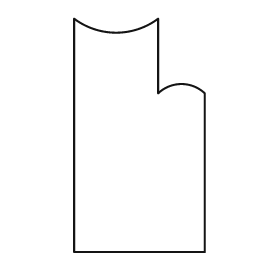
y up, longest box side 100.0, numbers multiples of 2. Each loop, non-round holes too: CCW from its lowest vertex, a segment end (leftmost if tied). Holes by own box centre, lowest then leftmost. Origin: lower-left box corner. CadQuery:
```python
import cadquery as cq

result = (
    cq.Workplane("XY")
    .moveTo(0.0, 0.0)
    .lineTo(56.0, 0.0)
    .lineTo(56.0, 68.0)
    .threePointArc((46.0, 72.0), (36.0, 68.0))
    .lineTo(36.0, 100.0)
    .threePointArc((18.0, 94.0), (0.0, 100.0))
    .close()
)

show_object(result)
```